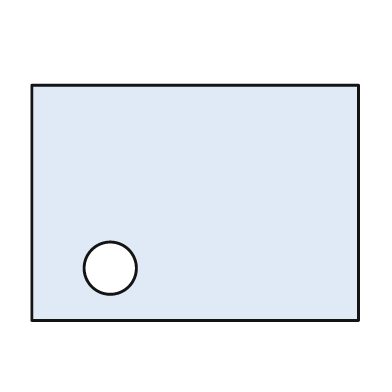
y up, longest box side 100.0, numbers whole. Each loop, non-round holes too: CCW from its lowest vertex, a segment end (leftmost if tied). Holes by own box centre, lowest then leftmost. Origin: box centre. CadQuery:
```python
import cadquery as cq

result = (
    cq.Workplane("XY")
    .moveTo(-50.0, -36.0)
    .lineTo(50.0, -36.0)
    .lineTo(50.0, 36.0)
    .lineTo(-50.0, 36.0)
    .close()
    .moveTo(-26.0, -20.0)
    .circle(8.0)
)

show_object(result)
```